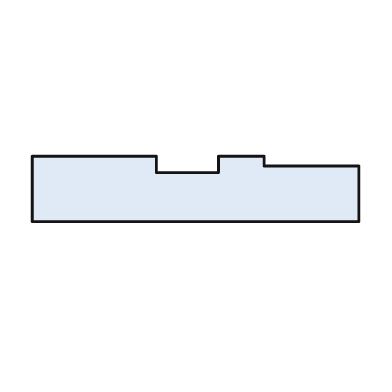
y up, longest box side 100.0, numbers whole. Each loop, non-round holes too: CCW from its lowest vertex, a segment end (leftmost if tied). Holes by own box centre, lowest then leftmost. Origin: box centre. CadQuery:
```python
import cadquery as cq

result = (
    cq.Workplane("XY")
    .moveTo(-50.0, -10.0)
    .lineTo(50.0, -10.0)
    .lineTo(50.0, 7.0)
    .lineTo(21.0, 7.0)
    .lineTo(21.0, 10.0)
    .lineTo(7.0, 10.0)
    .lineTo(7.0, 5.0)
    .lineTo(-12.0, 5.0)
    .lineTo(-12.0, 10.0)
    .lineTo(-50.0, 10.0)
    .close()
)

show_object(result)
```